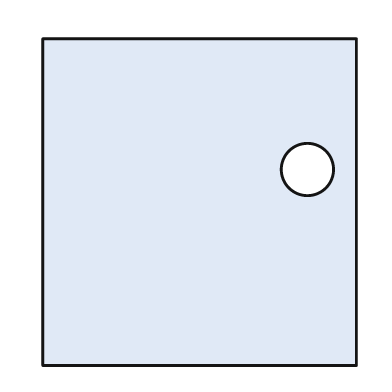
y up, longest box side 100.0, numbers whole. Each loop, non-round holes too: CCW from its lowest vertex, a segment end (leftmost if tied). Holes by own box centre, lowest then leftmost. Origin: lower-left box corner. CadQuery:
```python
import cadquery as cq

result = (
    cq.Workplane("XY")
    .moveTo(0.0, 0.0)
    .lineTo(96.0, 0.0)
    .lineTo(96.0, 100.0)
    .lineTo(0.0, 100.0)
    .close()
    .moveTo(81.0, 60.0)
    .circle(8.0)
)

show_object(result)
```